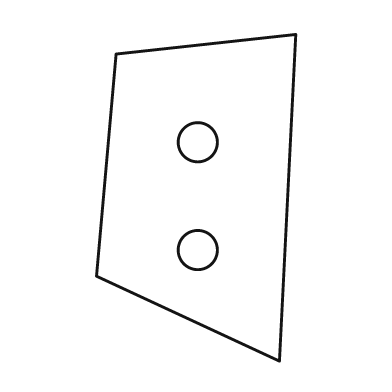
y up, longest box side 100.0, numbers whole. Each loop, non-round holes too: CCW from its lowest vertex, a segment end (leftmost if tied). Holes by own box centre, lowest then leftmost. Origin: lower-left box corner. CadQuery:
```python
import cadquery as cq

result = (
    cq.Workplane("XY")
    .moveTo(56.0, 0.0)
    .lineTo(61.0, 100.0)
    .lineTo(6.0, 94.0)
    .lineTo(0.0, 26.0)
    .close()
    .moveTo(31.0, 34.0)
    .circle(6.0)
    .moveTo(31.0, 67.0)
    .circle(6.0)
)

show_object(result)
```